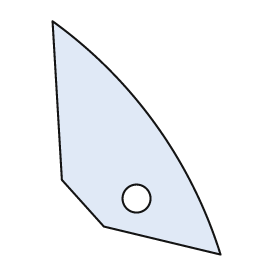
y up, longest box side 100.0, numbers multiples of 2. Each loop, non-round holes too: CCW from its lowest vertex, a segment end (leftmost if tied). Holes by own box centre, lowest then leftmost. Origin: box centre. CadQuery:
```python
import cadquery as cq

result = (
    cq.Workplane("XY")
    .moveTo(36.0, -50.0)
    .threePointArc((8.0, 6.0), (-36.0, 50.0))
    .lineTo(-32.0, -18.0)
    .lineTo(-14.0, -38.0)
    .close()
    .moveTo(0.0, -26.0)
    .circle(6.0)
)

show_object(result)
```